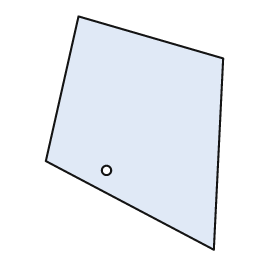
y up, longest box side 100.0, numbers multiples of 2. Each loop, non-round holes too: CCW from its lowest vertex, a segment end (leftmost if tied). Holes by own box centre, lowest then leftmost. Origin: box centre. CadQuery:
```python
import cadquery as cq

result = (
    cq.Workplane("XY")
    .moveTo(34.0, -50.0)
    .lineTo(38.0, 32.0)
    .lineTo(-24.0, 50.0)
    .lineTo(-38.0, -12.0)
    .close()
    .moveTo(-12.0, -16.0)
    .circle(2.0)
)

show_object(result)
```